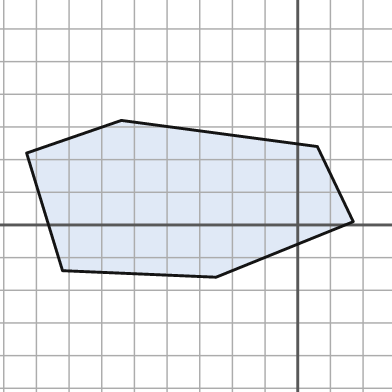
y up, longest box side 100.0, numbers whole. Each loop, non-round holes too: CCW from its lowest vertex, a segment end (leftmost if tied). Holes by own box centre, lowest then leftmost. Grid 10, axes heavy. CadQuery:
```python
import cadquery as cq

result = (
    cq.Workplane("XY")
    .moveTo(-25.0, -16.0)
    .lineTo(17.0, 1.0)
    .lineTo(6.0, 24.0)
    .lineTo(-54.0, 32.0)
    .lineTo(-83.0, 22.0)
    .lineTo(-72.0, -14.0)
    .close()
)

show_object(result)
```